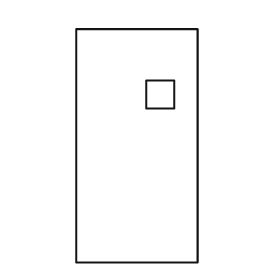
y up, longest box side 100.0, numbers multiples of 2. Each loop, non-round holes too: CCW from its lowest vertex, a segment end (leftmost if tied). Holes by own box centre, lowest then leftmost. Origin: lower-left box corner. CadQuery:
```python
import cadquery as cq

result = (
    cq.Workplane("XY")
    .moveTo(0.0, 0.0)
    .lineTo(52.0, 0.0)
    .lineTo(52.0, 100.0)
    .lineTo(0.0, 100.0)
    .close()
    .moveTo(30.0, 66.0)
    .lineTo(42.0, 66.0)
    .lineTo(42.0, 78.0)
    .lineTo(30.0, 78.0)
    .close()
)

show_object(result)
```